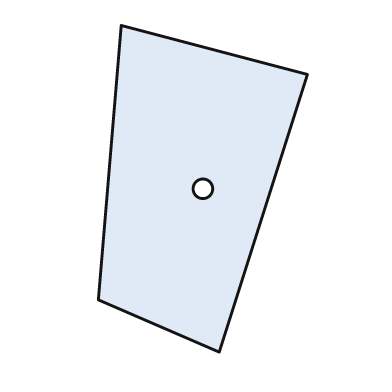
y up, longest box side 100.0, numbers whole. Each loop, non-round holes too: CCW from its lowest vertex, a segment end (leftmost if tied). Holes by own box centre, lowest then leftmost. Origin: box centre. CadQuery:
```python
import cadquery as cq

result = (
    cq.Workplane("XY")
    .moveTo(5.0, -50.0)
    .lineTo(32.0, 35.0)
    .lineTo(-25.0, 50.0)
    .lineTo(-32.0, -34.0)
    .close()
    .moveTo(0.0, 0.0)
    .circle(3.0)
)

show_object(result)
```